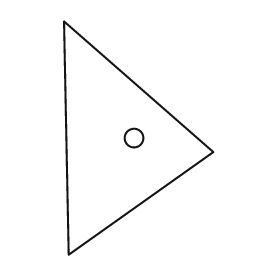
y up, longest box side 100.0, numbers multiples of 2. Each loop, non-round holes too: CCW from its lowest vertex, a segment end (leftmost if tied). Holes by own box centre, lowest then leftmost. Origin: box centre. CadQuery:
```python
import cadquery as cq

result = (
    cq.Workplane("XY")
    .moveTo(-30.0, -50.0)
    .lineTo(32.0, -6.0)
    .lineTo(-32.0, 50.0)
    .close()
    .moveTo(-2.0, 0.0)
    .circle(4.0)
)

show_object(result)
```